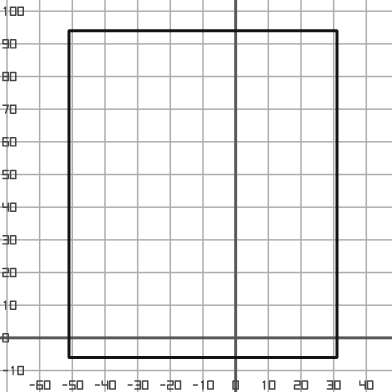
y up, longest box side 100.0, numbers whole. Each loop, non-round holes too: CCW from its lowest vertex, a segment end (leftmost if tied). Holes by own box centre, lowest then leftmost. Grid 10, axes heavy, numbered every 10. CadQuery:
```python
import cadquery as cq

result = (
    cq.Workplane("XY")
    .moveTo(-51.0, -6.0)
    .lineTo(31.0, -6.0)
    .lineTo(31.0, 94.0)
    .lineTo(-51.0, 94.0)
    .close()
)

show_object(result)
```